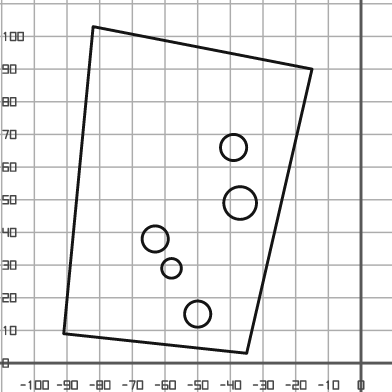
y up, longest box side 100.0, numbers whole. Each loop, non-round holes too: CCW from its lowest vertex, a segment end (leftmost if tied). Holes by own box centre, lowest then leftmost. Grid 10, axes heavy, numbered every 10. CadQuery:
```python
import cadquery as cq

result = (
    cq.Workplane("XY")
    .moveTo(-35.0, 3.0)
    .lineTo(-15.0, 90.0)
    .lineTo(-82.0, 103.0)
    .lineTo(-91.0, 9.0)
    .close()
    .moveTo(-50.0, 15.0)
    .circle(4.0)
    .moveTo(-58.0, 29.0)
    .circle(3.0)
    .moveTo(-63.0, 38.0)
    .circle(4.0)
    .moveTo(-37.0, 49.0)
    .circle(5.0)
    .moveTo(-39.0, 66.0)
    .circle(4.0)
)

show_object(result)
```